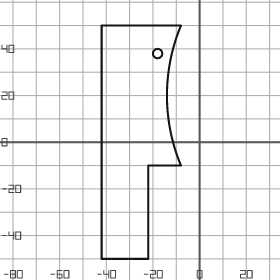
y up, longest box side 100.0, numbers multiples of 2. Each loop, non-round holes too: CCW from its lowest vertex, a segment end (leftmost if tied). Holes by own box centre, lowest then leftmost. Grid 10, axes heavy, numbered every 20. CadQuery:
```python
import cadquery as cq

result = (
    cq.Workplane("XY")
    .moveTo(-42.0, -50.0)
    .lineTo(-22.0, -50.0)
    .lineTo(-22.0, -10.0)
    .lineTo(-8.0, -10.0)
    .threePointArc((-14.0, 20.0), (-8.0, 50.0))
    .lineTo(-42.0, 50.0)
    .close()
    .moveTo(-18.0, 38.0)
    .circle(2.0)
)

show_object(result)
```